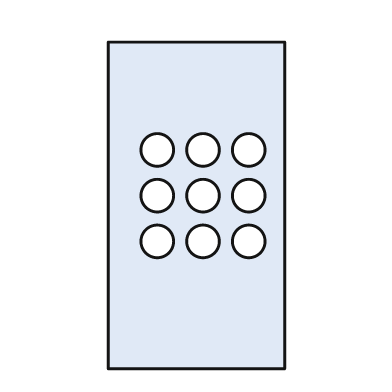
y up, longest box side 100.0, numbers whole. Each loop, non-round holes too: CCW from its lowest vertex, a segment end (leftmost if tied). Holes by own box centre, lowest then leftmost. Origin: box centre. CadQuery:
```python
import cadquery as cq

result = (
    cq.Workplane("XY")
    .moveTo(-27.0, -50.0)
    .lineTo(27.0, -50.0)
    .lineTo(27.0, 50.0)
    .lineTo(-27.0, 50.0)
    .close()
    .moveTo(-12.0, -11.0)
    .circle(5.0)
    .moveTo(2.0, -11.0)
    .circle(5.0)
    .moveTo(16.0, -11.0)
    .circle(5.0)
    .moveTo(-12.0, 3.0)
    .circle(5.0)
    .moveTo(2.0, 3.0)
    .circle(5.0)
    .moveTo(16.0, 3.0)
    .circle(5.0)
    .moveTo(-12.0, 17.0)
    .circle(5.0)
    .moveTo(2.0, 17.0)
    .circle(5.0)
    .moveTo(16.0, 17.0)
    .circle(5.0)
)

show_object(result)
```